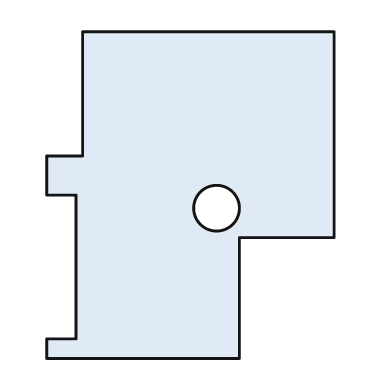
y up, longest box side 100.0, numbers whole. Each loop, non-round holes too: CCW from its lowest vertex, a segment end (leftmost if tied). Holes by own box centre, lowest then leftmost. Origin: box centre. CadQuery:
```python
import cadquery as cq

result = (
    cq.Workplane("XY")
    .moveTo(-44.0, -50.0)
    .lineTo(15.0, -50.0)
    .lineTo(15.0, -13.0)
    .lineTo(44.0, -13.0)
    .lineTo(44.0, 50.0)
    .lineTo(-33.0, 50.0)
    .lineTo(-33.0, 12.0)
    .lineTo(-44.0, 12.0)
    .lineTo(-44.0, 0.0)
    .lineTo(-35.0, 0.0)
    .lineTo(-35.0, -44.0)
    .lineTo(-44.0, -44.0)
    .close()
    .moveTo(8.0, -4.0)
    .circle(7.0)
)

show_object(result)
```